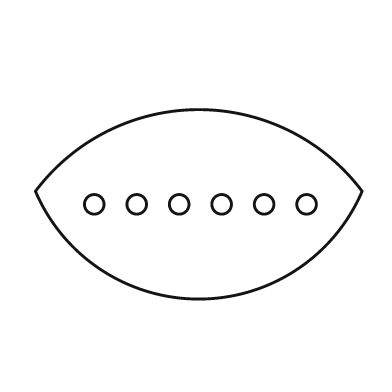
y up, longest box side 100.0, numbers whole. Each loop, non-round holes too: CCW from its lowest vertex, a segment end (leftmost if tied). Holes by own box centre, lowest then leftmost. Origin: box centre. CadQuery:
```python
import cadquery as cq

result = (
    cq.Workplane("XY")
    .moveTo(-50.0, 4.0)
    .threePointArc((0.0, -29.0), (50.0, 4.0))
    .threePointArc((0.0, 29.0), (-50.0, 4.0))
    .close()
    .moveTo(-32.0, 0.0)
    .circle(3.0)
    .moveTo(-19.0, 0.0)
    .circle(3.0)
    .moveTo(-6.0, 0.0)
    .circle(3.0)
    .moveTo(7.0, 0.0)
    .circle(3.0)
    .moveTo(20.0, 0.0)
    .circle(3.0)
    .moveTo(33.0, 0.0)
    .circle(3.0)
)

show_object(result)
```